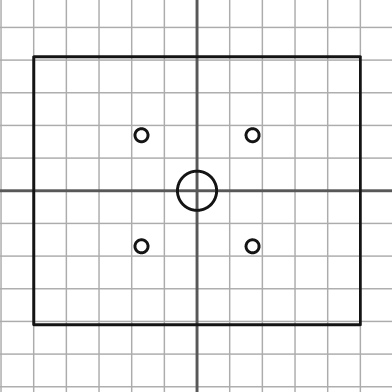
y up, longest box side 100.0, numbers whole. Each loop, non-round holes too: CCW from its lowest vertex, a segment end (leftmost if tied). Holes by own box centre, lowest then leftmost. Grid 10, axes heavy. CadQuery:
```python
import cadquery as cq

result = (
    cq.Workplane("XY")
    .moveTo(-50.0, -41.0)
    .lineTo(50.0, -41.0)
    .lineTo(50.0, 41.0)
    .lineTo(-50.0, 41.0)
    .close()
    .moveTo(-17.0, -17.0)
    .circle(2.0)
    .moveTo(17.0, -17.0)
    .circle(2.0)
    .moveTo(0.0, 0.0)
    .circle(6.0)
    .moveTo(-17.0, 17.0)
    .circle(2.0)
    .moveTo(17.0, 17.0)
    .circle(2.0)
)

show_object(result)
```